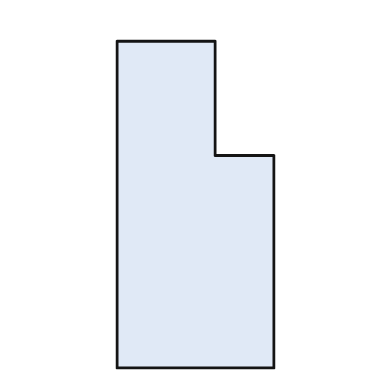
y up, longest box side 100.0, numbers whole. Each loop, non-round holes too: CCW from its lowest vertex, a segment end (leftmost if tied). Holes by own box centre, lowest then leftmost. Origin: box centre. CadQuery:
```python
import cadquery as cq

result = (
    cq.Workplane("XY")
    .moveTo(-24.0, -50.0)
    .lineTo(24.0, -50.0)
    .lineTo(24.0, 15.0)
    .lineTo(6.0, 15.0)
    .lineTo(6.0, 50.0)
    .lineTo(-24.0, 50.0)
    .close()
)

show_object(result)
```